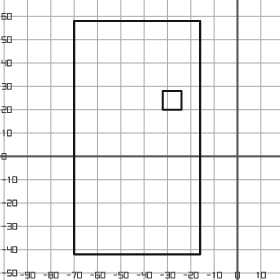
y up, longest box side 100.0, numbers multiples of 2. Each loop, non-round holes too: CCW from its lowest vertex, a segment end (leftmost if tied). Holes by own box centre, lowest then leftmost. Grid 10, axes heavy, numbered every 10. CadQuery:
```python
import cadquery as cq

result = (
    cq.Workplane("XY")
    .moveTo(-70.0, -42.0)
    .lineTo(-16.0, -42.0)
    .lineTo(-16.0, 58.0)
    .lineTo(-70.0, 58.0)
    .close()
    .moveTo(-32.0, 20.0)
    .lineTo(-24.0, 20.0)
    .lineTo(-24.0, 28.0)
    .lineTo(-32.0, 28.0)
    .close()
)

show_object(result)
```